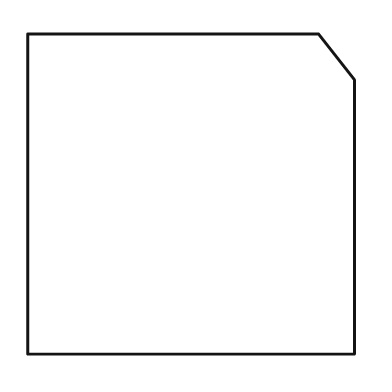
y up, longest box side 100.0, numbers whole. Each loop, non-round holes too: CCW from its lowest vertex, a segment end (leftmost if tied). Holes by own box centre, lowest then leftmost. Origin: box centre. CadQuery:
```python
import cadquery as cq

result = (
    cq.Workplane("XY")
    .moveTo(-50.0, -49.0)
    .lineTo(50.0, -49.0)
    .lineTo(50.0, 35.0)
    .lineTo(39.0, 49.0)
    .lineTo(-50.0, 49.0)
    .close()
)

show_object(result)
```